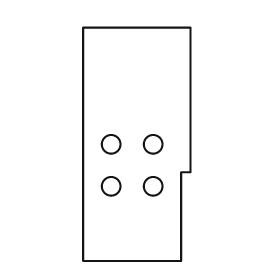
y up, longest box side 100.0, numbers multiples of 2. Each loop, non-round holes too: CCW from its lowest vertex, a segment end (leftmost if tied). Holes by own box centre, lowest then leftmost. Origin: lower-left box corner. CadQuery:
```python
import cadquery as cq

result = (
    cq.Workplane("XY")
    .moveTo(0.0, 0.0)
    .lineTo(42.0, 0.0)
    .lineTo(42.0, 38.0)
    .lineTo(46.0, 38.0)
    .lineTo(46.0, 100.0)
    .lineTo(0.0, 100.0)
    .close()
    .moveTo(12.0, 32.0)
    .circle(4.0)
    .moveTo(30.0, 32.0)
    .circle(4.0)
    .moveTo(12.0, 50.0)
    .circle(4.0)
    .moveTo(30.0, 50.0)
    .circle(4.0)
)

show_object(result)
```